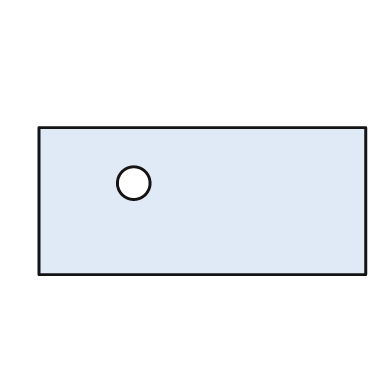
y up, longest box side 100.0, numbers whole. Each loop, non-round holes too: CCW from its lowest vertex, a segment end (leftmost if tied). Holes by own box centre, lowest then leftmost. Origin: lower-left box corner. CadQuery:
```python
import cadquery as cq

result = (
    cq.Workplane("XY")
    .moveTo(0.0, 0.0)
    .lineTo(100.0, 0.0)
    .lineTo(100.0, 45.0)
    .lineTo(0.0, 45.0)
    .close()
    .moveTo(29.0, 28.0)
    .circle(5.0)
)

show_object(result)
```